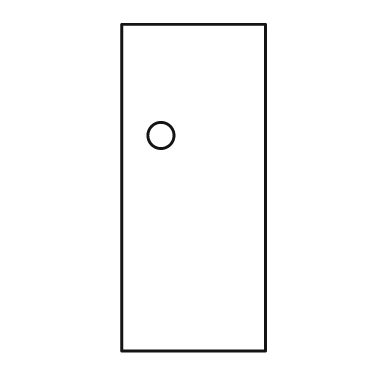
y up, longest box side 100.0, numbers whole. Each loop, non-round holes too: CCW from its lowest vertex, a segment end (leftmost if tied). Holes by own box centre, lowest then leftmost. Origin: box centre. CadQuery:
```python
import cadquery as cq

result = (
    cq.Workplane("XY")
    .moveTo(-22.0, -50.0)
    .lineTo(22.0, -50.0)
    .lineTo(22.0, 50.0)
    .lineTo(-22.0, 50.0)
    .close()
    .moveTo(-10.0, 16.0)
    .circle(4.0)
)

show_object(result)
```